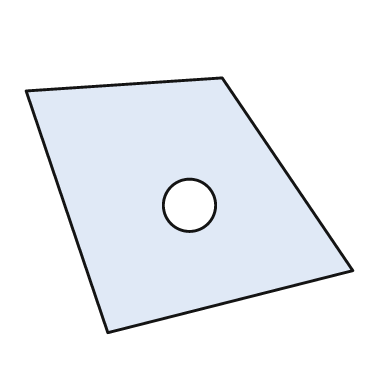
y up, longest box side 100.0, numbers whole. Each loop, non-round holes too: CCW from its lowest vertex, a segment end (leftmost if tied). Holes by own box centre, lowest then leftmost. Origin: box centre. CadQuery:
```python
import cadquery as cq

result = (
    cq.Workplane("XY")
    .moveTo(-25.0, -39.0)
    .lineTo(50.0, -20.0)
    .lineTo(10.0, 39.0)
    .lineTo(-50.0, 35.0)
    .close()
    .moveTo(0.0, 0.0)
    .circle(8.0)
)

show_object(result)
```